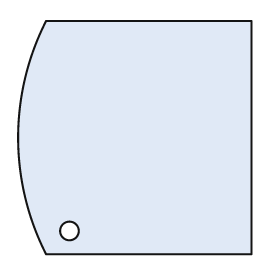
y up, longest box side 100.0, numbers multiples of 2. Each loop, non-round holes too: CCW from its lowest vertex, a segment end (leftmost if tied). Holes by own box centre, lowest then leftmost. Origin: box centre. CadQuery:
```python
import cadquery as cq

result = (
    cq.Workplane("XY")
    .moveTo(-38.0, -50.0)
    .lineTo(50.0, -50.0)
    .lineTo(50.0, 50.0)
    .lineTo(-38.0, 50.0)
    .threePointArc((-50.0, 0.0), (-38.0, -50.0))
    .close()
    .moveTo(-28.0, -40.0)
    .circle(4.0)
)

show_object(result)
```